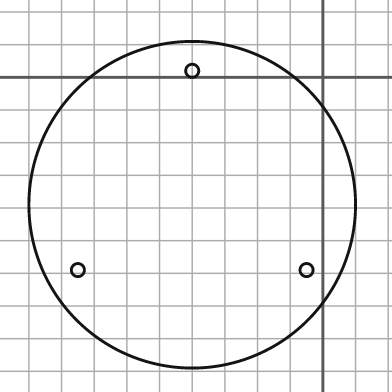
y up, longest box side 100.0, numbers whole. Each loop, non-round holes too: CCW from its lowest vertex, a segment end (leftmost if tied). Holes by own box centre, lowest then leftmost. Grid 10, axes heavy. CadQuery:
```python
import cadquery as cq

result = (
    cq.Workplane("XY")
    .moveTo(-40.0, -39.0)
    .circle(50.0)
    .moveTo(-75.0, -59.0)
    .circle(2.0)
    .moveTo(-5.0, -59.0)
    .circle(2.0)
    .moveTo(-40.0, 2.0)
    .circle(2.0)
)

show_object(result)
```